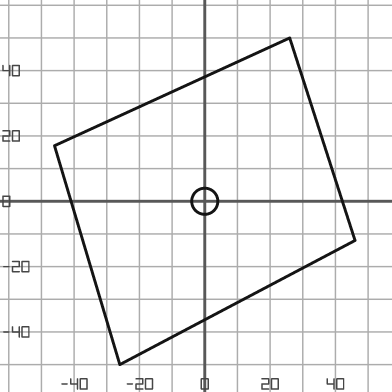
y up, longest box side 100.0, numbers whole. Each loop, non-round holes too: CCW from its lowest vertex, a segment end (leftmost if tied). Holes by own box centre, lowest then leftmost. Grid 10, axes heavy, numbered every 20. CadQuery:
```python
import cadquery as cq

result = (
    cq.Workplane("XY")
    .moveTo(-26.0, -50.0)
    .lineTo(46.0, -12.0)
    .lineTo(26.0, 50.0)
    .lineTo(-46.0, 17.0)
    .close()
    .moveTo(0.0, 0.0)
    .circle(4.0)
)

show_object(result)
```